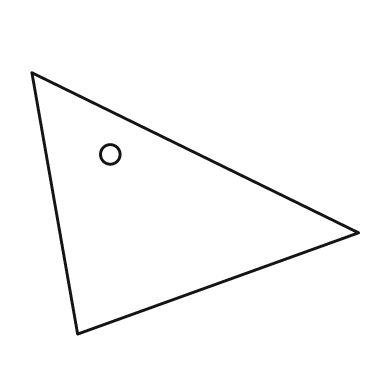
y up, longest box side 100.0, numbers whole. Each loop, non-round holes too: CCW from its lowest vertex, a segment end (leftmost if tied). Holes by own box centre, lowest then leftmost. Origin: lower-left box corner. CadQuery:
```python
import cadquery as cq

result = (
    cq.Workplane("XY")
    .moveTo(14.0, 0.0)
    .lineTo(100.0, 31.0)
    .lineTo(0.0, 80.0)
    .close()
    .moveTo(24.0, 55.0)
    .circle(3.0)
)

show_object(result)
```